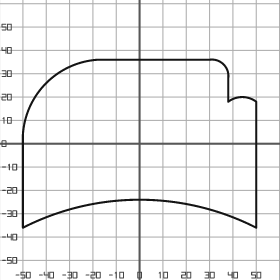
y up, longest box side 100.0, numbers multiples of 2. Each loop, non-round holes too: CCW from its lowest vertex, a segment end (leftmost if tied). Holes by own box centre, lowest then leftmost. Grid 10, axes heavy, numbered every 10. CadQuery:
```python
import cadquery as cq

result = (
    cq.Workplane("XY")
    .moveTo(-50.0, -36.0)
    .threePointArc((0.0, -24.0), (50.0, -36.0))
    .lineTo(50.0, 18.0)
    .threePointArc((44.0, 20.0), (38.0, 18.0))
    .lineTo(38.0, 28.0)
    .threePointArc((36.0, 34.0), (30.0, 36.0))
    .lineTo(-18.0, 36.0)
    .threePointArc((-40.0, 26.0), (-50.0, 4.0))
    .close()
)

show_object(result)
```